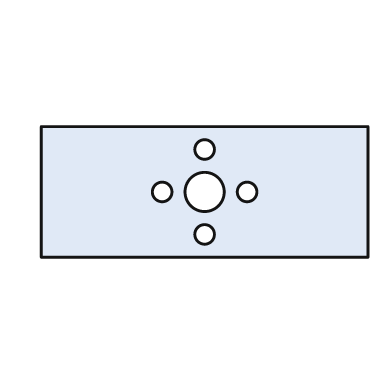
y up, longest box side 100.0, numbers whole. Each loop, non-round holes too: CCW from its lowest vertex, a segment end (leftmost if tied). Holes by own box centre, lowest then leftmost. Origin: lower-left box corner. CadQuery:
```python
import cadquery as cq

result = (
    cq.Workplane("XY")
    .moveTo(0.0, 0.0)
    .lineTo(100.0, 0.0)
    .lineTo(100.0, 40.0)
    .lineTo(0.0, 40.0)
    .close()
    .moveTo(50.0, 7.0)
    .circle(3.0)
    .moveTo(37.0, 20.0)
    .circle(3.0)
    .moveTo(50.0, 20.0)
    .circle(6.0)
    .moveTo(63.0, 20.0)
    .circle(3.0)
    .moveTo(50.0, 33.0)
    .circle(3.0)
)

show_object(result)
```